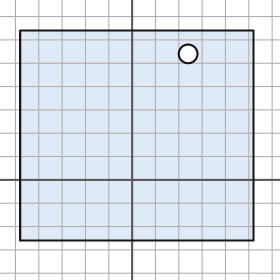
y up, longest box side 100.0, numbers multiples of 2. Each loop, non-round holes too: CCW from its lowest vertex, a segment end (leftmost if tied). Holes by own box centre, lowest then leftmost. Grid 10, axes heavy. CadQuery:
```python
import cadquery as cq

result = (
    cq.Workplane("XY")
    .moveTo(-48.0, -26.0)
    .lineTo(52.0, -26.0)
    .lineTo(52.0, 64.0)
    .lineTo(-48.0, 64.0)
    .close()
    .moveTo(24.0, 54.0)
    .circle(4.0)
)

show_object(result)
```